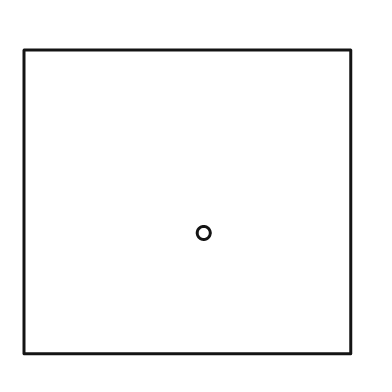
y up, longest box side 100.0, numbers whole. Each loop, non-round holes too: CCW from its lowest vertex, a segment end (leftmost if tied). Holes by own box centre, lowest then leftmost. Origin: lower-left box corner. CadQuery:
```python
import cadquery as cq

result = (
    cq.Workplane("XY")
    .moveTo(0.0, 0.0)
    .lineTo(100.0, 0.0)
    .lineTo(100.0, 93.0)
    .lineTo(0.0, 93.0)
    .close()
    .moveTo(55.0, 37.0)
    .circle(2.0)
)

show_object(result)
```